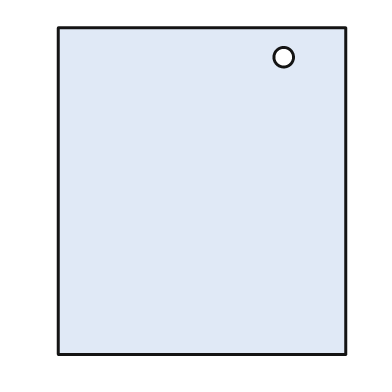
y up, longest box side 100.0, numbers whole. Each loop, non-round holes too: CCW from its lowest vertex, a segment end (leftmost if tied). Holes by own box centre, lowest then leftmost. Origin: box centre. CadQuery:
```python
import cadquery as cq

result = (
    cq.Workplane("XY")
    .moveTo(-44.0, -50.0)
    .lineTo(44.0, -50.0)
    .lineTo(44.0, 50.0)
    .lineTo(-44.0, 50.0)
    .close()
    .moveTo(25.0, 41.0)
    .circle(3.0)
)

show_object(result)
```